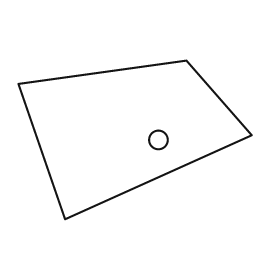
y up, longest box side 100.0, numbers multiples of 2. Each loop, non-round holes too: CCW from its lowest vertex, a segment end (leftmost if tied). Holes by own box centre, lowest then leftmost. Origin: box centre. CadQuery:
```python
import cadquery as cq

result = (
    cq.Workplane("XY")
    .moveTo(-30.0, -34.0)
    .lineTo(50.0, 2.0)
    .lineTo(22.0, 34.0)
    .lineTo(-50.0, 24.0)
    .close()
    .moveTo(10.0, 0.0)
    .circle(4.0)
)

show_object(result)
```